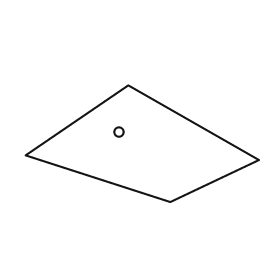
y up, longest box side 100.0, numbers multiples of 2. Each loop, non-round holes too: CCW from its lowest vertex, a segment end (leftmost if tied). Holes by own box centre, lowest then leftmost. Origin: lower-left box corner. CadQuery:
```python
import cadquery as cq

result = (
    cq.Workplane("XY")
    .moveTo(62.0, 0.0)
    .lineTo(100.0, 18.0)
    .lineTo(44.0, 50.0)
    .lineTo(0.0, 20.0)
    .close()
    .moveTo(40.0, 30.0)
    .circle(2.0)
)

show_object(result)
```